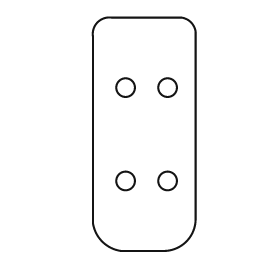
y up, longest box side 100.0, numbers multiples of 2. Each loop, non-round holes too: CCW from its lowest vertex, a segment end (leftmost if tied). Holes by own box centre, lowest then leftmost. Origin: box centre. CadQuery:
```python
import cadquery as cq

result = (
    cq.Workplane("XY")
    .moveTo(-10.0, -50.0)
    .lineTo(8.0, -50.0)
    .threePointArc((18.0, -46.0), (22.0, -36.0))
    .lineTo(22.0, 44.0)
    .threePointArc((20.0, 48.0), (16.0, 50.0))
    .lineTo(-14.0, 50.0)
    .threePointArc((-20.0, 48.0), (-22.0, 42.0))
    .lineTo(-22.0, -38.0)
    .threePointArc((-18.0, -46.0), (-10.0, -50.0))
    .close()
    .moveTo(-8.0, -20.0)
    .circle(4.0)
    .moveTo(10.0, -20.0)
    .circle(4.0)
    .moveTo(-8.0, 20.0)
    .circle(4.0)
    .moveTo(10.0, 20.0)
    .circle(4.0)
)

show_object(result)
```